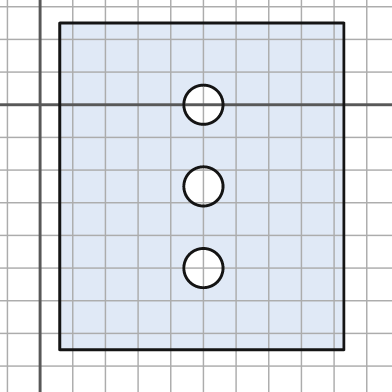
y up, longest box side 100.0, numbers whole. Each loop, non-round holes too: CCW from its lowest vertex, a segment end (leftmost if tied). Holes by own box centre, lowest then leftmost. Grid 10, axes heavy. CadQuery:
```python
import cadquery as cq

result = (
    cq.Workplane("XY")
    .moveTo(6.0, -75.0)
    .lineTo(93.0, -75.0)
    .lineTo(93.0, 25.0)
    .lineTo(6.0, 25.0)
    .close()
    .moveTo(50.0, -50.0)
    .circle(6.0)
    .moveTo(50.0, -25.0)
    .circle(6.0)
    .moveTo(50.0, 0.0)
    .circle(6.0)
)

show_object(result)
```